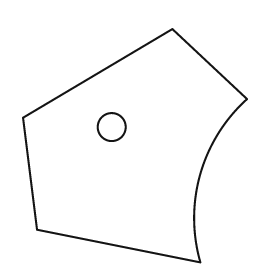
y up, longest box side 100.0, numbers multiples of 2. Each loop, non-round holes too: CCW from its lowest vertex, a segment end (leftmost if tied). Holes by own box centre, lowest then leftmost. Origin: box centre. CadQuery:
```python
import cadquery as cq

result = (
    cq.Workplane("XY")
    .moveTo(28.0, -50.0)
    .threePointArc((28.0, -12.0), (48.0, 20.0))
    .lineTo(16.0, 50.0)
    .lineTo(-48.0, 12.0)
    .lineTo(-42.0, -36.0)
    .close()
    .moveTo(-10.0, 8.0)
    .circle(6.0)
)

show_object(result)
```